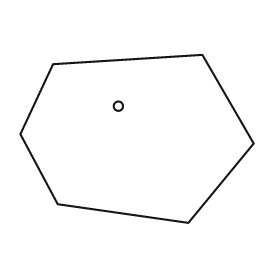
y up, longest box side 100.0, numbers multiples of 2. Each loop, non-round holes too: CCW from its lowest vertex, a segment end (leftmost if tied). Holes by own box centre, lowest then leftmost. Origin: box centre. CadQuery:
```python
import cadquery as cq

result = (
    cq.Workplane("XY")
    .moveTo(22.0, -36.0)
    .lineTo(50.0, -2.0)
    .lineTo(28.0, 36.0)
    .lineTo(-36.0, 32.0)
    .lineTo(-50.0, 2.0)
    .lineTo(-34.0, -28.0)
    .close()
    .moveTo(-8.0, 14.0)
    .circle(2.0)
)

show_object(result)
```